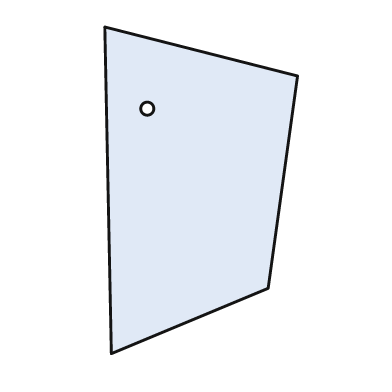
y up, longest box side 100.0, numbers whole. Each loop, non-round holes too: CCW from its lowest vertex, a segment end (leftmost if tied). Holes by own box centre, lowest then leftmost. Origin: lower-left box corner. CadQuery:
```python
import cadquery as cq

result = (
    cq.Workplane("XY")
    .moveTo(2.0, 0.0)
    .lineTo(50.0, 20.0)
    .lineTo(59.0, 85.0)
    .lineTo(0.0, 100.0)
    .close()
    .moveTo(13.0, 75.0)
    .circle(2.0)
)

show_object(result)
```